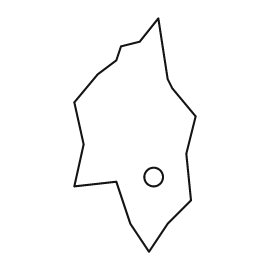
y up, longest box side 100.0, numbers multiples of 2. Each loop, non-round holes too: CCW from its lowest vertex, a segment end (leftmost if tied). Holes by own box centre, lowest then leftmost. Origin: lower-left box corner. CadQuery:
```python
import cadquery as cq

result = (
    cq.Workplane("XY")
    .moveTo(32.0, 0.0)
    .lineTo(40.0, 12.0)
    .lineTo(50.0, 22.0)
    .lineTo(48.0, 42.0)
    .lineTo(52.0, 58.0)
    .lineTo(42.0, 70.0)
    .lineTo(40.0, 74.0)
    .lineTo(36.0, 100.0)
    .lineTo(28.0, 90.0)
    .lineTo(20.0, 88.0)
    .lineTo(18.0, 82.0)
    .lineTo(10.0, 76.0)
    .lineTo(0.0, 64.0)
    .lineTo(4.0, 46.0)
    .lineTo(0.0, 28.0)
    .lineTo(18.0, 30.0)
    .lineTo(24.0, 12.0)
    .close()
    .moveTo(34.0, 32.0)
    .circle(4.0)
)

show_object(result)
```